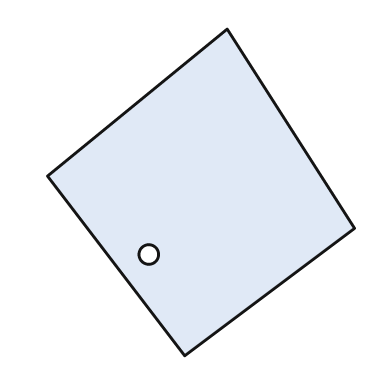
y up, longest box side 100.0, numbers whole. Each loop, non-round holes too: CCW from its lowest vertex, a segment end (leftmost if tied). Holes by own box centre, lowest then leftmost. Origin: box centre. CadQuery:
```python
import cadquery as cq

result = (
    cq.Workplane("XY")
    .moveTo(-5.0, -50.0)
    .lineTo(47.0, -11.0)
    .lineTo(8.0, 50.0)
    .lineTo(-47.0, 5.0)
    .close()
    .moveTo(-16.0, -19.0)
    .circle(3.0)
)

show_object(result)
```